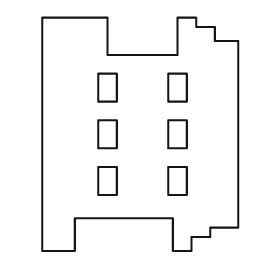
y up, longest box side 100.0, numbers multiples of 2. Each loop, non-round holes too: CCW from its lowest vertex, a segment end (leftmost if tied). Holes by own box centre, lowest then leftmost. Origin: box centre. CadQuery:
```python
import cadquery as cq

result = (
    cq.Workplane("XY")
    .moveTo(-42.0, -50.0)
    .lineTo(-28.0, -50.0)
    .lineTo(-28.0, -36.0)
    .lineTo(14.0, -36.0)
    .lineTo(14.0, -50.0)
    .lineTo(22.0, -50.0)
    .lineTo(22.0, -44.0)
    .lineTo(30.0, -44.0)
    .lineTo(30.0, -40.0)
    .lineTo(42.0, -40.0)
    .lineTo(42.0, 40.0)
    .lineTo(32.0, 40.0)
    .lineTo(32.0, 46.0)
    .lineTo(24.0, 46.0)
    .lineTo(24.0, 50.0)
    .lineTo(16.0, 50.0)
    .lineTo(16.0, 34.0)
    .lineTo(-14.0, 34.0)
    .lineTo(-14.0, 50.0)
    .lineTo(-42.0, 50.0)
    .close()
    .moveTo(-18.0, -26.0)
    .lineTo(-10.0, -26.0)
    .lineTo(-10.0, -14.0)
    .lineTo(-18.0, -14.0)
    .close()
    .moveTo(12.0, -26.0)
    .lineTo(20.0, -26.0)
    .lineTo(20.0, -14.0)
    .lineTo(12.0, -14.0)
    .close()
    .moveTo(-18.0, -6.0)
    .lineTo(-10.0, -6.0)
    .lineTo(-10.0, 6.0)
    .lineTo(-18.0, 6.0)
    .close()
    .moveTo(12.0, -6.0)
    .lineTo(20.0, -6.0)
    .lineTo(20.0, 6.0)
    .lineTo(12.0, 6.0)
    .close()
    .moveTo(-18.0, 14.0)
    .lineTo(-10.0, 14.0)
    .lineTo(-10.0, 26.0)
    .lineTo(-18.0, 26.0)
    .close()
    .moveTo(12.0, 14.0)
    .lineTo(20.0, 14.0)
    .lineTo(20.0, 26.0)
    .lineTo(12.0, 26.0)
    .close()
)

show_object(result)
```